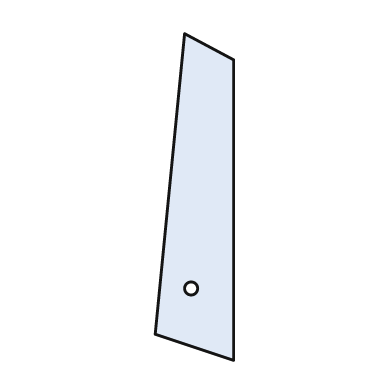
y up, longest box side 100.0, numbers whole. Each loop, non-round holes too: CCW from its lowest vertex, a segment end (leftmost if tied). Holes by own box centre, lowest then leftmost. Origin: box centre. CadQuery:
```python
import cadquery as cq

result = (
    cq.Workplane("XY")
    .moveTo(12.0, -50.0)
    .lineTo(12.0, 42.0)
    .lineTo(-3.0, 50.0)
    .lineTo(-12.0, -42.0)
    .close()
    .moveTo(-1.0, -28.0)
    .circle(2.0)
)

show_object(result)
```